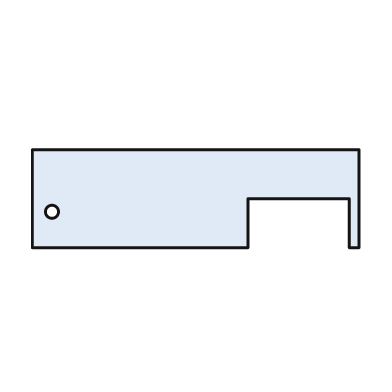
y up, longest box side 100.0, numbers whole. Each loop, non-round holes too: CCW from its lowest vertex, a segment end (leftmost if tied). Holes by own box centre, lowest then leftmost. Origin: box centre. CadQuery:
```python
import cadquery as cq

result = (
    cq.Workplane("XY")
    .moveTo(-50.0, -15.0)
    .lineTo(16.0, -15.0)
    .lineTo(16.0, 0.0)
    .lineTo(47.0, 0.0)
    .lineTo(47.0, -15.0)
    .lineTo(50.0, -15.0)
    .lineTo(50.0, 15.0)
    .lineTo(-50.0, 15.0)
    .close()
    .moveTo(-44.0, -4.0)
    .circle(2.0)
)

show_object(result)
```